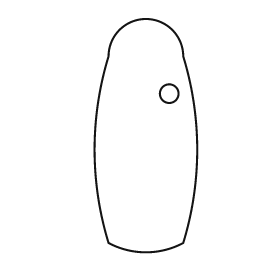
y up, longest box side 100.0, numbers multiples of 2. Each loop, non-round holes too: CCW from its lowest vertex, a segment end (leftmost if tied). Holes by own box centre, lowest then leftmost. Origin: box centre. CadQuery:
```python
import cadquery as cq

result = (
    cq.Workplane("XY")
    .moveTo(-16.0, -46.0)
    .threePointArc((0.0, -50.0), (16.0, -46.0))
    .threePointArc((22.0, -6.0), (16.0, 34.0))
    .threePointArc((0.0, 50.0), (-16.0, 34.0))
    .threePointArc((-22.0, -6.0), (-16.0, -46.0))
    .close()
    .moveTo(10.0, 18.0)
    .circle(4.0)
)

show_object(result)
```